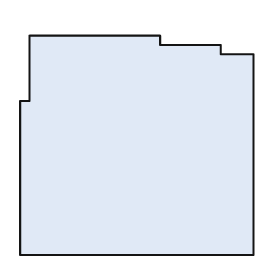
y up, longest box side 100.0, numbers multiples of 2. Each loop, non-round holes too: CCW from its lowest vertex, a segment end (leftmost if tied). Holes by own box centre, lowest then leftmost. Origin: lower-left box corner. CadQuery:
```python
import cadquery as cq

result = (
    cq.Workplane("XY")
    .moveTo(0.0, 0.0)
    .lineTo(100.0, 0.0)
    .lineTo(100.0, 86.0)
    .lineTo(86.0, 86.0)
    .lineTo(86.0, 90.0)
    .lineTo(60.0, 90.0)
    .lineTo(60.0, 94.0)
    .lineTo(4.0, 94.0)
    .lineTo(4.0, 66.0)
    .lineTo(0.0, 66.0)
    .close()
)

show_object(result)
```